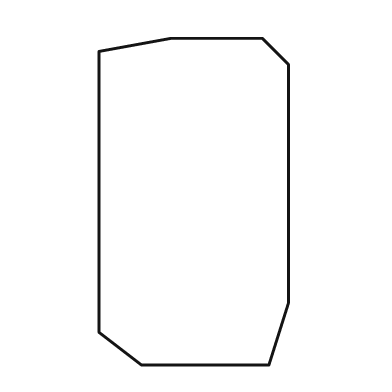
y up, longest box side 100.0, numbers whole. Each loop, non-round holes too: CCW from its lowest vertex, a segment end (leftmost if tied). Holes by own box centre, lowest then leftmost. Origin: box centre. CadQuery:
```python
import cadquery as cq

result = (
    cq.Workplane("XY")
    .moveTo(-16.0, -50.0)
    .lineTo(23.0, -50.0)
    .lineTo(29.0, -31.0)
    .lineTo(29.0, 42.0)
    .lineTo(21.0, 50.0)
    .lineTo(-7.0, 50.0)
    .lineTo(-29.0, 46.0)
    .lineTo(-29.0, -40.0)
    .close()
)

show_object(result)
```